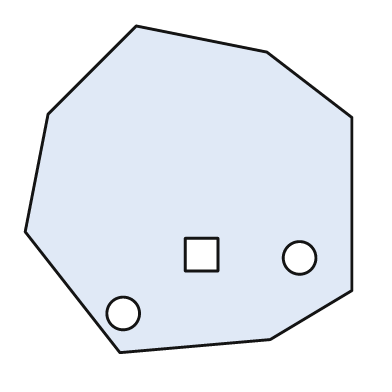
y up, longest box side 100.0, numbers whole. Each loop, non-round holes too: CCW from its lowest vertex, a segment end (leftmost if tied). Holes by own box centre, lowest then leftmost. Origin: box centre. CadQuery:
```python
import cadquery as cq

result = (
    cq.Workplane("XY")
    .moveTo(-21.0, -50.0)
    .lineTo(25.0, -46.0)
    .lineTo(50.0, -31.0)
    .lineTo(50.0, 22.0)
    .lineTo(24.0, 42.0)
    .lineTo(-16.0, 50.0)
    .lineTo(-43.0, 23.0)
    .lineTo(-50.0, -13.0)
    .close()
    .moveTo(-20.0, -38.0)
    .circle(5.0)
    .moveTo(34.0, -21.0)
    .circle(5.0)
    .moveTo(-1.0, -25.0)
    .lineTo(9.0, -25.0)
    .lineTo(9.0, -15.0)
    .lineTo(-1.0, -15.0)
    .close()
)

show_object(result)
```